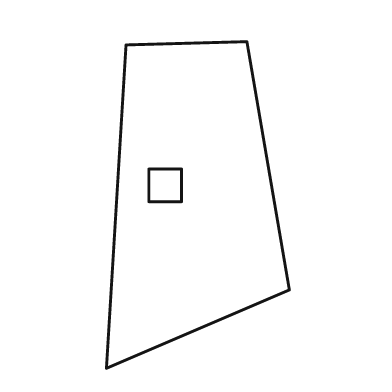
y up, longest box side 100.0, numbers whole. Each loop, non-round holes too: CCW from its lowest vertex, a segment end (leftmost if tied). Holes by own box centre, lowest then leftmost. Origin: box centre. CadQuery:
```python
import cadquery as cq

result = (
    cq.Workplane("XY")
    .moveTo(-28.0, -50.0)
    .lineTo(28.0, -26.0)
    .lineTo(15.0, 50.0)
    .lineTo(-22.0, 49.0)
    .close()
    .moveTo(-15.0, 1.0)
    .lineTo(-5.0, 1.0)
    .lineTo(-5.0, 11.0)
    .lineTo(-15.0, 11.0)
    .close()
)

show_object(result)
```